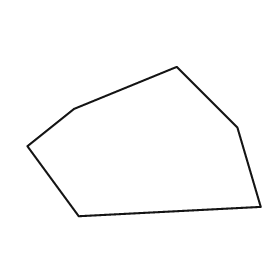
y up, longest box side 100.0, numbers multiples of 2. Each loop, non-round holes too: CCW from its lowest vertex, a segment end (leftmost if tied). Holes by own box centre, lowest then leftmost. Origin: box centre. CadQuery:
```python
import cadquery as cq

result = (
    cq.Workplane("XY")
    .moveTo(-28.0, -32.0)
    .lineTo(50.0, -28.0)
    .lineTo(40.0, 6.0)
    .lineTo(14.0, 32.0)
    .lineTo(-30.0, 14.0)
    .lineTo(-50.0, -2.0)
    .close()
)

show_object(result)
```